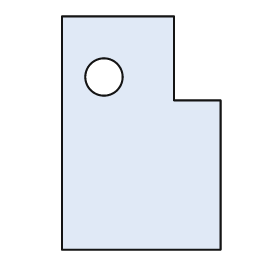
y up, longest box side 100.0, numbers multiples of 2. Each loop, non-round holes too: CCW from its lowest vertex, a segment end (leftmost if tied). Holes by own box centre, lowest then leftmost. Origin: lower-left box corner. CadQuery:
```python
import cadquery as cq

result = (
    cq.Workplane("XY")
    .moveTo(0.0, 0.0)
    .lineTo(68.0, 0.0)
    .lineTo(68.0, 64.0)
    .lineTo(48.0, 64.0)
    .lineTo(48.0, 100.0)
    .lineTo(0.0, 100.0)
    .close()
    .moveTo(18.0, 74.0)
    .circle(8.0)
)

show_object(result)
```